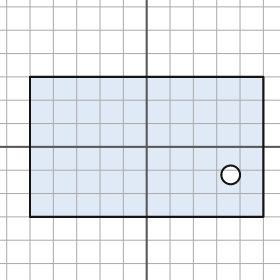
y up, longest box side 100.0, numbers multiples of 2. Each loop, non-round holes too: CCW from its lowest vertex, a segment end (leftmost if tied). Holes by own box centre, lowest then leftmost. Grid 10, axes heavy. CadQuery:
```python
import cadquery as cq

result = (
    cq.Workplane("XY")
    .moveTo(-50.0, -30.0)
    .lineTo(50.0, -30.0)
    .lineTo(50.0, 30.0)
    .lineTo(-50.0, 30.0)
    .close()
    .moveTo(36.0, -12.0)
    .circle(4.0)
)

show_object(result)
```